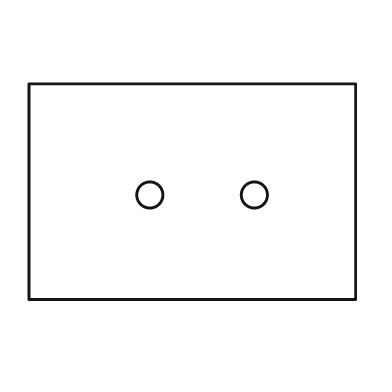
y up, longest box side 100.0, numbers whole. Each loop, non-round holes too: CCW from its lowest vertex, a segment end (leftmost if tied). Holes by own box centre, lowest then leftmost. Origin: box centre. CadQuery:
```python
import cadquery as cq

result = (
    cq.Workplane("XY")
    .moveTo(-50.0, -33.0)
    .lineTo(50.0, -33.0)
    .lineTo(50.0, 33.0)
    .lineTo(-50.0, 33.0)
    .close()
    .moveTo(-13.0, -1.0)
    .circle(4.0)
    .moveTo(19.0, -1.0)
    .circle(4.0)
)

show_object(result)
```